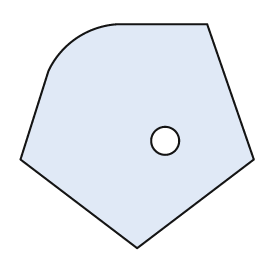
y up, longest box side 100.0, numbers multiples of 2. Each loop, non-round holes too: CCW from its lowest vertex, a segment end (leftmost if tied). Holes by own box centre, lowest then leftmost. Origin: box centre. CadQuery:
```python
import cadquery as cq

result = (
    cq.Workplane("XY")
    .moveTo(0.0, -48.0)
    .lineTo(50.0, -10.0)
    .lineTo(30.0, 48.0)
    .lineTo(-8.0, 48.0)
    .threePointArc((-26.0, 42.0), (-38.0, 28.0))
    .lineTo(-50.0, -10.0)
    .close()
    .moveTo(12.0, -2.0)
    .circle(6.0)
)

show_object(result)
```